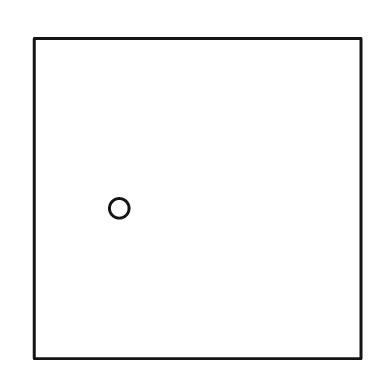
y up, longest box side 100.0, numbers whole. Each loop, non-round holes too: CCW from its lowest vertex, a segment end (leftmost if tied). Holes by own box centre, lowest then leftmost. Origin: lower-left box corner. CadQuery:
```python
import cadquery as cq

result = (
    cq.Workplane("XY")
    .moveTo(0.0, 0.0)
    .lineTo(100.0, 0.0)
    .lineTo(100.0, 98.0)
    .lineTo(0.0, 98.0)
    .close()
    .moveTo(26.0, 46.0)
    .circle(3.0)
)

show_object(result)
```